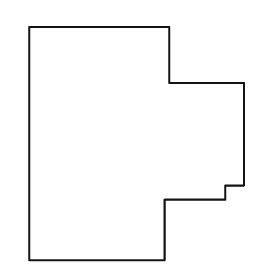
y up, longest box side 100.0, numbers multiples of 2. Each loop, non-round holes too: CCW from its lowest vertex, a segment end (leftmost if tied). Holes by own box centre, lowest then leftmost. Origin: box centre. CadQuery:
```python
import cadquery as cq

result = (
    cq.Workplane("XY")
    .moveTo(-46.0, -50.0)
    .lineTo(12.0, -50.0)
    .lineTo(12.0, -24.0)
    .lineTo(38.0, -24.0)
    .lineTo(38.0, -18.0)
    .lineTo(46.0, -18.0)
    .lineTo(46.0, 26.0)
    .lineTo(14.0, 26.0)
    .lineTo(14.0, 50.0)
    .lineTo(-46.0, 50.0)
    .close()
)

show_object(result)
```